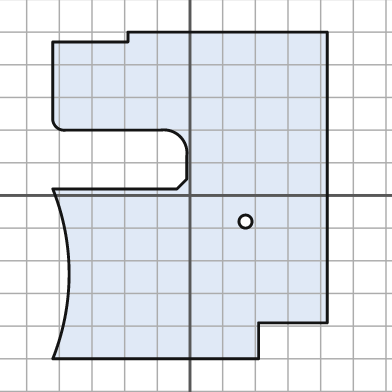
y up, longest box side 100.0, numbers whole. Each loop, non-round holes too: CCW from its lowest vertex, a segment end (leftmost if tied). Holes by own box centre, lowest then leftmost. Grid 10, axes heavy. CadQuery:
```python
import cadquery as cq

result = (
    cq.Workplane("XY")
    .moveTo(-42.0, -50.0)
    .lineTo(21.0, -50.0)
    .lineTo(21.0, -39.0)
    .lineTo(42.0, -39.0)
    .lineTo(42.0, 50.0)
    .lineTo(-19.0, 50.0)
    .lineTo(-19.0, 47.0)
    .lineTo(-42.0, 47.0)
    .lineTo(-42.0, 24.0)
    .threePointArc((-41.0, 21.0), (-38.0, 20.0))
    .lineTo(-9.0, 20.0)
    .threePointArc((-3.0, 18.0), (-1.0, 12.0))
    .lineTo(-1.0, 5.0)
    .lineTo(-4.0, 2.0)
    .lineTo(-42.0, 2.0)
    .threePointArc((-37.0, -24.0), (-42.0, -50.0))
    .close()
    .moveTo(17.0, -8.0)
    .circle(2.0)
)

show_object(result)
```